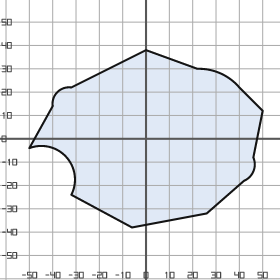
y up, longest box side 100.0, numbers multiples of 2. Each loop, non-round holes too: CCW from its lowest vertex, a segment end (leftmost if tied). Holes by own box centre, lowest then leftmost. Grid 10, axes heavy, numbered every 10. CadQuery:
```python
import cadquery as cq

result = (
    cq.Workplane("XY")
    .moveTo(-6.0, -38.0)
    .lineTo(26.0, -32.0)
    .lineTo(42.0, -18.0)
    .threePointArc((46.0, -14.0), (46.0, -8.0))
    .lineTo(50.0, 12.0)
    .lineTo(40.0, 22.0)
    .threePointArc((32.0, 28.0), (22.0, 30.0))
    .lineTo(0.0, 38.0)
    .lineTo(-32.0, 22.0)
    .threePointArc((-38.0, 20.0), (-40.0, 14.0))
    .lineTo(-50.0, -4.0)
    .threePointArc((-34.0, -8.0), (-32.0, -24.0))
    .close()
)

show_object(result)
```